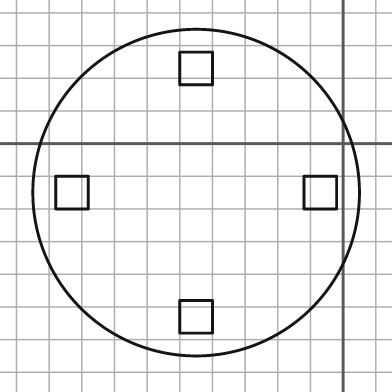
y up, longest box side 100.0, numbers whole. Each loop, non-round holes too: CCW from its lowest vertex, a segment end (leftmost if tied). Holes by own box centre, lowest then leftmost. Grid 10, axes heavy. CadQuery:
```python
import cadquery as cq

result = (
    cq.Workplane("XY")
    .moveTo(-45.0, -15.0)
    .circle(50.0)
    .moveTo(-50.0, -58.0)
    .lineTo(-40.0, -58.0)
    .lineTo(-40.0, -48.0)
    .lineTo(-50.0, -48.0)
    .close()
    .moveTo(-88.0, -20.0)
    .lineTo(-78.0, -20.0)
    .lineTo(-78.0, -10.0)
    .lineTo(-88.0, -10.0)
    .close()
    .moveTo(-12.0, -20.0)
    .lineTo(-2.0, -20.0)
    .lineTo(-2.0, -10.0)
    .lineTo(-12.0, -10.0)
    .close()
    .moveTo(-50.0, 18.0)
    .lineTo(-40.0, 18.0)
    .lineTo(-40.0, 28.0)
    .lineTo(-50.0, 28.0)
    .close()
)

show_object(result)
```